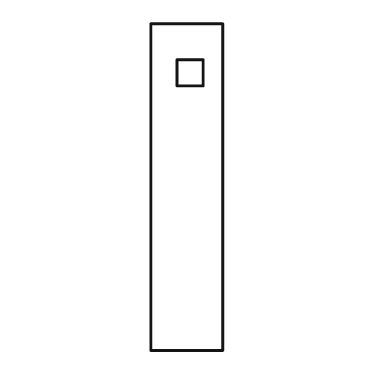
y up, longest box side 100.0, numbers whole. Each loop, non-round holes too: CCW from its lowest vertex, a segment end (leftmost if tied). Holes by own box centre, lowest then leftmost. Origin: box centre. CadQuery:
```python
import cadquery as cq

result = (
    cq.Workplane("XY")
    .moveTo(-11.0, -50.0)
    .lineTo(11.0, -50.0)
    .lineTo(11.0, 50.0)
    .lineTo(-11.0, 50.0)
    .close()
    .moveTo(-3.0, 31.0)
    .lineTo(5.0, 31.0)
    .lineTo(5.0, 39.0)
    .lineTo(-3.0, 39.0)
    .close()
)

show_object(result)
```